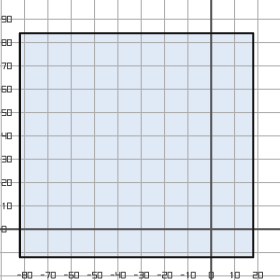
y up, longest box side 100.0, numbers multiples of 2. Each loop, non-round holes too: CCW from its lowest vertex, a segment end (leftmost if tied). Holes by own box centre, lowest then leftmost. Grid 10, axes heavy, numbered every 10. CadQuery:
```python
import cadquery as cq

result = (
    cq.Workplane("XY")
    .moveTo(-82.0, -12.0)
    .lineTo(18.0, -12.0)
    .lineTo(18.0, 84.0)
    .lineTo(-82.0, 84.0)
    .close()
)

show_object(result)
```